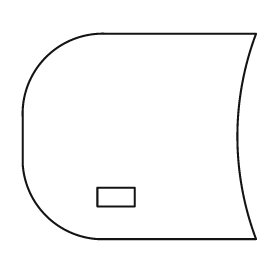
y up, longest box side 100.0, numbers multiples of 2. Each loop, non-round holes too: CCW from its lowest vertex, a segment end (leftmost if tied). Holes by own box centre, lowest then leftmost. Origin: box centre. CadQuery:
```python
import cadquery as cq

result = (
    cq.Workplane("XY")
    .moveTo(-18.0, -44.0)
    .lineTo(50.0, -44.0)
    .threePointArc((42.0, 0.0), (50.0, 44.0))
    .lineTo(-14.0, 44.0)
    .threePointArc((-40.0, 34.0), (-50.0, 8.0))
    .lineTo(-50.0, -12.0)
    .threePointArc((-40.0, -34.0), (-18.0, -44.0))
    .close()
    .moveTo(-18.0, -30.0)
    .lineTo(-2.0, -30.0)
    .lineTo(-2.0, -22.0)
    .lineTo(-18.0, -22.0)
    .close()
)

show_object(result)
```